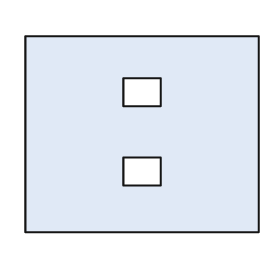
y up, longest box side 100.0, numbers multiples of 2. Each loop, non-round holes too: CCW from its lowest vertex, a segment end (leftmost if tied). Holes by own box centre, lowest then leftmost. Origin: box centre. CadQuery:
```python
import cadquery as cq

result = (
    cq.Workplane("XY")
    .moveTo(-50.0, -42.0)
    .lineTo(50.0, -42.0)
    .lineTo(50.0, 42.0)
    .lineTo(-50.0, 42.0)
    .close()
    .moveTo(-8.0, -22.0)
    .lineTo(8.0, -22.0)
    .lineTo(8.0, -10.0)
    .lineTo(-8.0, -10.0)
    .close()
    .moveTo(-8.0, 12.0)
    .lineTo(8.0, 12.0)
    .lineTo(8.0, 24.0)
    .lineTo(-8.0, 24.0)
    .close()
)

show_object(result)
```